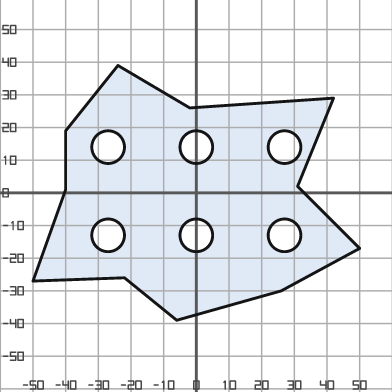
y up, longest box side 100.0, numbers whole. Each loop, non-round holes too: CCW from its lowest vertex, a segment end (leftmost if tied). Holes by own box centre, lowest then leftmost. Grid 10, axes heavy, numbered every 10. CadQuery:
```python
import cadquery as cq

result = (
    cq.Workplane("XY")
    .moveTo(-6.0, -39.0)
    .lineTo(26.0, -30.0)
    .lineTo(50.0, -17.0)
    .lineTo(31.0, 2.0)
    .lineTo(42.0, 29.0)
    .lineTo(-2.0, 26.0)
    .lineTo(-24.0, 39.0)
    .lineTo(-40.0, 19.0)
    .lineTo(-40.0, 1.0)
    .lineTo(-50.0, -27.0)
    .lineTo(-22.0, -26.0)
    .close()
    .moveTo(-27.0, -13.0)
    .circle(5.0)
    .moveTo(0.0, -13.0)
    .circle(5.0)
    .moveTo(27.0, -13.0)
    .circle(5.0)
    .moveTo(-27.0, 14.0)
    .circle(5.0)
    .moveTo(0.0, 14.0)
    .circle(5.0)
    .moveTo(27.0, 14.0)
    .circle(5.0)
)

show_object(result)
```